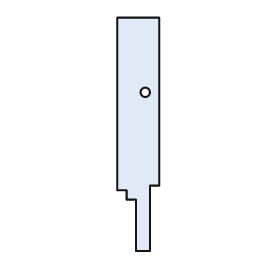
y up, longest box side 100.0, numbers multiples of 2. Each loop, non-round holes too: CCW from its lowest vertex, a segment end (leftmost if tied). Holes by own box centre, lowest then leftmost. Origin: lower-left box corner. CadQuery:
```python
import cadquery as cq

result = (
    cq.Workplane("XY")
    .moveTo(8.0, 0.0)
    .lineTo(14.0, 0.0)
    .lineTo(14.0, 28.0)
    .lineTo(18.0, 28.0)
    .lineTo(18.0, 100.0)
    .lineTo(0.0, 100.0)
    .lineTo(0.0, 26.0)
    .lineTo(4.0, 26.0)
    .lineTo(4.0, 22.0)
    .lineTo(8.0, 22.0)
    .close()
    .moveTo(12.0, 68.0)
    .circle(2.0)
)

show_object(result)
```